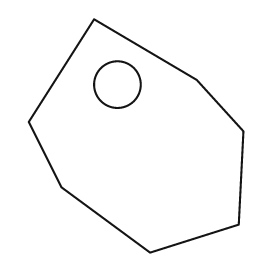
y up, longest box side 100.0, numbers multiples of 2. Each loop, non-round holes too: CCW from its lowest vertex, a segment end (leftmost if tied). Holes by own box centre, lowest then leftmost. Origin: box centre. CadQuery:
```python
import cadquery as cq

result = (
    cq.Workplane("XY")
    .moveTo(6.0, -50.0)
    .lineTo(44.0, -38.0)
    .lineTo(46.0, 2.0)
    .lineTo(26.0, 24.0)
    .lineTo(-18.0, 50.0)
    .lineTo(-46.0, 6.0)
    .lineTo(-32.0, -22.0)
    .close()
    .moveTo(-8.0, 22.0)
    .circle(10.0)
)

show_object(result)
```